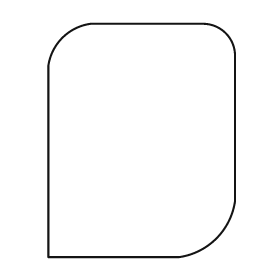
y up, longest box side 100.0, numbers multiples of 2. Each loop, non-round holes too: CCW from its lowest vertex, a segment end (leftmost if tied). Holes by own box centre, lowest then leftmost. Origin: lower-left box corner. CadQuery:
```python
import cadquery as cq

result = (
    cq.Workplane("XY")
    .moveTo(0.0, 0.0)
    .lineTo(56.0, 0.0)
    .threePointArc((72.0, 8.0), (80.0, 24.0))
    .lineTo(80.0, 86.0)
    .threePointArc((76.0, 96.0), (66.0, 100.0))
    .lineTo(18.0, 100.0)
    .threePointArc((6.0, 94.0), (0.0, 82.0))
    .close()
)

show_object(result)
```